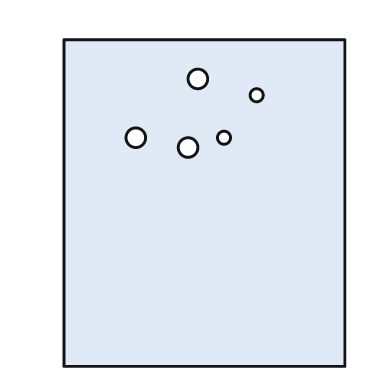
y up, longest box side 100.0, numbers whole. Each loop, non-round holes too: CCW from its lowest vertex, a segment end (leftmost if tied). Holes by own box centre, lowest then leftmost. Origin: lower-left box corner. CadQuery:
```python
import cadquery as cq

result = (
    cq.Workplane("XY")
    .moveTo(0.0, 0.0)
    .lineTo(86.0, 0.0)
    .lineTo(86.0, 100.0)
    .lineTo(0.0, 100.0)
    .close()
    .moveTo(38.0, 67.0)
    .circle(3.0)
    .moveTo(22.0, 70.0)
    .circle(3.0)
    .moveTo(49.0, 70.0)
    .circle(2.0)
    .moveTo(59.0, 83.0)
    .circle(2.0)
    .moveTo(41.0, 88.0)
    .circle(3.0)
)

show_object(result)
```